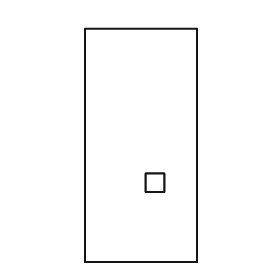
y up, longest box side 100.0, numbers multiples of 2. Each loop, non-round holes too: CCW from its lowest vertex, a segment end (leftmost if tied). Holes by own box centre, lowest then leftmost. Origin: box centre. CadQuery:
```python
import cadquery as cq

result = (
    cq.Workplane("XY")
    .moveTo(-24.0, -50.0)
    .lineTo(24.0, -50.0)
    .lineTo(24.0, 50.0)
    .lineTo(-24.0, 50.0)
    .close()
    .moveTo(2.0, -20.0)
    .lineTo(10.0, -20.0)
    .lineTo(10.0, -12.0)
    .lineTo(2.0, -12.0)
    .close()
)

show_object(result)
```